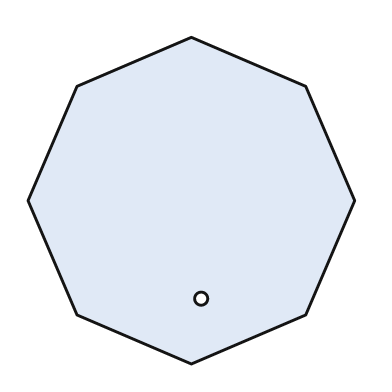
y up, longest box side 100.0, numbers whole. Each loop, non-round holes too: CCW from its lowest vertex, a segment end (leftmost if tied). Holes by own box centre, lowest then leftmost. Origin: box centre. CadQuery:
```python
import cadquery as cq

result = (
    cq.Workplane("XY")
    .moveTo(0.0, -50.0)
    .lineTo(35.0, -35.0)
    .lineTo(50.0, 0.0)
    .lineTo(35.0, 35.0)
    .lineTo(0.0, 50.0)
    .lineTo(-35.0, 35.0)
    .lineTo(-50.0, 0.0)
    .lineTo(-35.0, -35.0)
    .close()
    .moveTo(3.0, -30.0)
    .circle(2.0)
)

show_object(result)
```